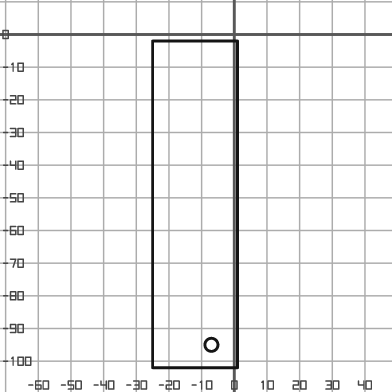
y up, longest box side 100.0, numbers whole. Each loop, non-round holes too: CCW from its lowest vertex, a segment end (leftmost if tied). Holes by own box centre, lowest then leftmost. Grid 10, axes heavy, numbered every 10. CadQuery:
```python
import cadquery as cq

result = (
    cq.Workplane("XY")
    .moveTo(-25.0, -102.0)
    .lineTo(1.0, -102.0)
    .lineTo(1.0, -2.0)
    .lineTo(-25.0, -2.0)
    .close()
    .moveTo(-7.0, -95.0)
    .circle(2.0)
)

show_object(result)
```